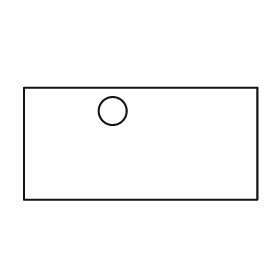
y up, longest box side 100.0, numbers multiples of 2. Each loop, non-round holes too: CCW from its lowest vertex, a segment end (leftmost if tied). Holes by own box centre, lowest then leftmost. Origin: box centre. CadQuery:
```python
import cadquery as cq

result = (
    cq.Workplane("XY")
    .moveTo(-50.0, -24.0)
    .lineTo(50.0, -24.0)
    .lineTo(50.0, 24.0)
    .lineTo(-50.0, 24.0)
    .close()
    .moveTo(-12.0, 14.0)
    .circle(6.0)
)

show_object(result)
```